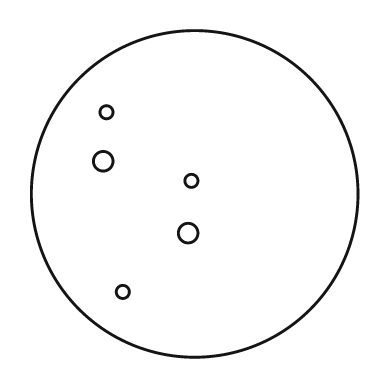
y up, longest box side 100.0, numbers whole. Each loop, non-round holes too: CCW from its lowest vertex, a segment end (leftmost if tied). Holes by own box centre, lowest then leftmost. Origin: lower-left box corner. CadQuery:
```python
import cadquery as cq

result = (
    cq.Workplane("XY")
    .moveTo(50.0, 50.0)
    .circle(50.0)
    .moveTo(28.0, 20.0)
    .circle(2.0)
    .moveTo(48.0, 38.0)
    .circle(3.0)
    .moveTo(49.0, 54.0)
    .circle(2.0)
    .moveTo(22.0, 60.0)
    .circle(3.0)
    .moveTo(23.0, 75.0)
    .circle(2.0)
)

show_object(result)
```